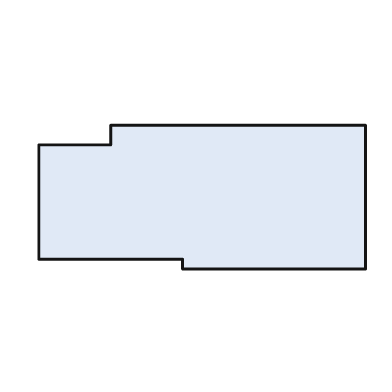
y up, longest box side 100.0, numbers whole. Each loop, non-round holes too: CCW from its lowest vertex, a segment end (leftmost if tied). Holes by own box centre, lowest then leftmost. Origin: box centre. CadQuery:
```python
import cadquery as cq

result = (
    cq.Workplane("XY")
    .moveTo(-6.0, -22.0)
    .lineTo(50.0, -22.0)
    .lineTo(50.0, 22.0)
    .lineTo(-28.0, 22.0)
    .lineTo(-28.0, 16.0)
    .lineTo(-50.0, 16.0)
    .lineTo(-50.0, -19.0)
    .lineTo(-6.0, -19.0)
    .close()
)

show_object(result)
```